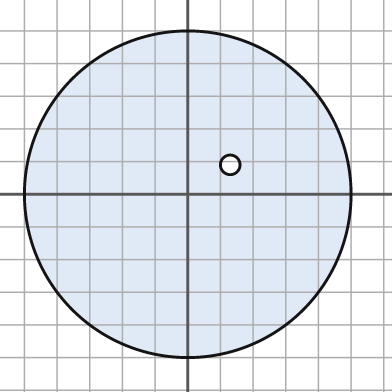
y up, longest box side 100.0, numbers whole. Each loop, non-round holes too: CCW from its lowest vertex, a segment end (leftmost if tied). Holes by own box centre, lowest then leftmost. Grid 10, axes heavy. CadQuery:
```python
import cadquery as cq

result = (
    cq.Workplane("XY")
    .moveTo(0.0, 0.0)
    .circle(50.0)
    .moveTo(13.0, 9.0)
    .circle(3.0)
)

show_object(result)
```